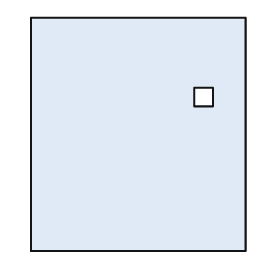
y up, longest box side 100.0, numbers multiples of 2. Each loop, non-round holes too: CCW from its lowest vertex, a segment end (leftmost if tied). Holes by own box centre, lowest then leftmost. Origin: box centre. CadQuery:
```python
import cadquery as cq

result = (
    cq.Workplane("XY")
    .moveTo(-46.0, -50.0)
    .lineTo(46.0, -50.0)
    .lineTo(46.0, 50.0)
    .lineTo(-46.0, 50.0)
    .close()
    .moveTo(24.0, 12.0)
    .lineTo(32.0, 12.0)
    .lineTo(32.0, 20.0)
    .lineTo(24.0, 20.0)
    .close()
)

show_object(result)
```